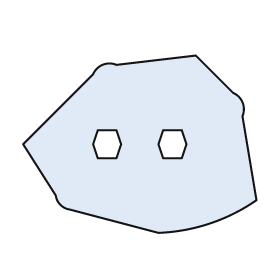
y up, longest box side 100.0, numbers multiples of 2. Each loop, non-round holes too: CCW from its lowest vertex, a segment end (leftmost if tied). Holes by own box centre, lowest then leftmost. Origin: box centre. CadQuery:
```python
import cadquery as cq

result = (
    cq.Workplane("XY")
    .moveTo(8.0, -38.0)
    .threePointArc((30.0, -34.0), (50.0, -24.0))
    .lineTo(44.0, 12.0)
    .threePointArc((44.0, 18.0), (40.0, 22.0))
    .lineTo(24.0, 38.0)
    .lineTo(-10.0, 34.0)
    .threePointArc((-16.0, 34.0), (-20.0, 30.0))
    .lineTo(-50.0, 0.0)
    .lineTo(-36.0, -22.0)
    .threePointArc((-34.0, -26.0), (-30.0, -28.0))
    .close()
    .moveTo(-18.0, -6.0)
    .lineTo(-10.0, -6.0)
    .lineTo(-8.0, 0.0)
    .lineTo(-10.0, 6.0)
    .lineTo(-18.0, 6.0)
    .lineTo(-20.0, 0.0)
    .close()
    .moveTo(10.0, -6.0)
    .lineTo(18.0, -6.0)
    .lineTo(20.0, 0.0)
    .lineTo(18.0, 6.0)
    .lineTo(10.0, 6.0)
    .lineTo(8.0, 0.0)
    .close()
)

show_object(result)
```